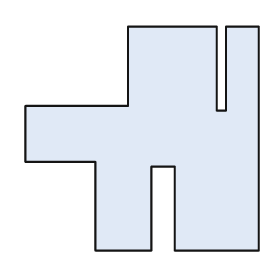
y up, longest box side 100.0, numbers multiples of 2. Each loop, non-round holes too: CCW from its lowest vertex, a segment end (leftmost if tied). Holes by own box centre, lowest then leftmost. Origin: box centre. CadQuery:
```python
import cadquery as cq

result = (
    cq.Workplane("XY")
    .moveTo(-20.0, -48.0)
    .lineTo(4.0, -48.0)
    .lineTo(4.0, -12.0)
    .lineTo(14.0, -12.0)
    .lineTo(14.0, -48.0)
    .lineTo(50.0, -48.0)
    .lineTo(50.0, 48.0)
    .lineTo(36.0, 48.0)
    .lineTo(36.0, 12.0)
    .lineTo(32.0, 12.0)
    .lineTo(32.0, 48.0)
    .lineTo(-6.0, 48.0)
    .lineTo(-6.0, 14.0)
    .lineTo(-50.0, 14.0)
    .lineTo(-50.0, -10.0)
    .lineTo(-20.0, -10.0)
    .close()
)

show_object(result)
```